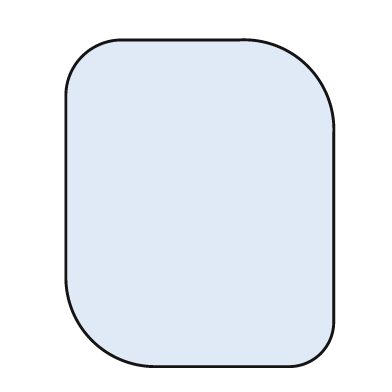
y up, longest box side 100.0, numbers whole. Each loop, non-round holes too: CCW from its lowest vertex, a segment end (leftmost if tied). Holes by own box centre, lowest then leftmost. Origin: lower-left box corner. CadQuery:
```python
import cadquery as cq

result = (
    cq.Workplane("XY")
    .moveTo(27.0, 0.0)
    .lineTo(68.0, 0.0)
    .threePointArc((78.0, 4.0), (82.0, 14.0))
    .lineTo(82.0, 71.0)
    .threePointArc((74.0, 92.0), (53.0, 100.0))
    .lineTo(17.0, 100.0)
    .threePointArc((5.0, 95.0), (0.0, 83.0))
    .lineTo(0.0, 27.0)
    .threePointArc((8.0, 8.0), (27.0, 0.0))
    .close()
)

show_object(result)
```